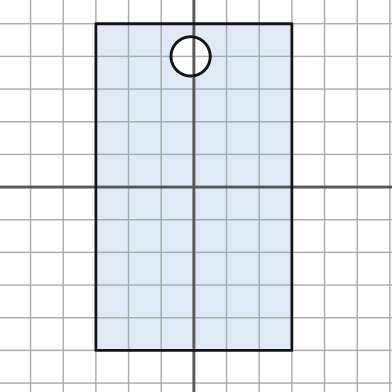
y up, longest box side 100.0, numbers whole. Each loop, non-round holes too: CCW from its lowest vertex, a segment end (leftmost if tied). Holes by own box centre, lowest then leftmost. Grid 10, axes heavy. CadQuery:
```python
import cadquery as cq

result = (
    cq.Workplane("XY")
    .moveTo(-30.0, -50.0)
    .lineTo(30.0, -50.0)
    .lineTo(30.0, 50.0)
    .lineTo(-30.0, 50.0)
    .close()
    .moveTo(-1.0, 40.0)
    .circle(6.0)
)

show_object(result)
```